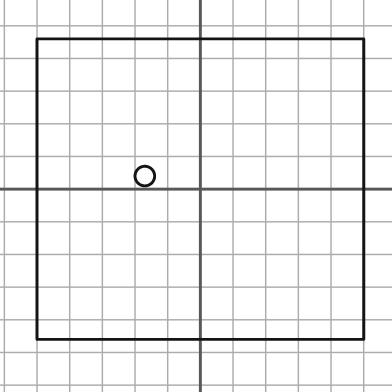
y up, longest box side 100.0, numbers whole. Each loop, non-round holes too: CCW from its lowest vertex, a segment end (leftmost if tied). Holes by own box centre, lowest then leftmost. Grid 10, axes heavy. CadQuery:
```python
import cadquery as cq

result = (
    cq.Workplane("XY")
    .moveTo(-50.0, -46.0)
    .lineTo(50.0, -46.0)
    .lineTo(50.0, 46.0)
    .lineTo(-50.0, 46.0)
    .close()
    .moveTo(-17.0, 4.0)
    .circle(3.0)
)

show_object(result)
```